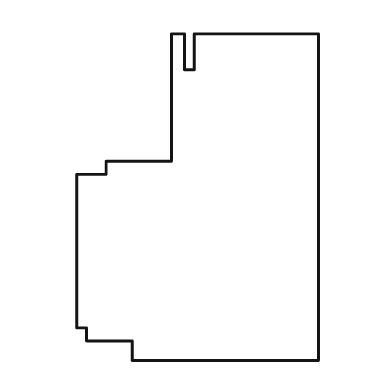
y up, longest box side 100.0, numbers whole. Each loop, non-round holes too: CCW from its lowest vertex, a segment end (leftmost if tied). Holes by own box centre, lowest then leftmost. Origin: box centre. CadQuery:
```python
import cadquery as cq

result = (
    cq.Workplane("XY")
    .moveTo(-20.0, -50.0)
    .lineTo(37.0, -50.0)
    .lineTo(37.0, 50.0)
    .lineTo(-1.0, 50.0)
    .lineTo(-1.0, 39.0)
    .lineTo(-4.0, 39.0)
    .lineTo(-4.0, 50.0)
    .lineTo(-8.0, 50.0)
    .lineTo(-8.0, 11.0)
    .lineTo(-28.0, 11.0)
    .lineTo(-28.0, 7.0)
    .lineTo(-37.0, 7.0)
    .lineTo(-37.0, -40.0)
    .lineTo(-34.0, -40.0)
    .lineTo(-34.0, -44.0)
    .lineTo(-20.0, -44.0)
    .close()
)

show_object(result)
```